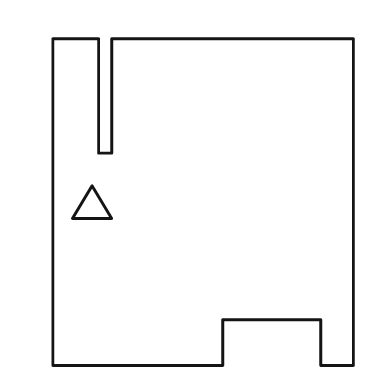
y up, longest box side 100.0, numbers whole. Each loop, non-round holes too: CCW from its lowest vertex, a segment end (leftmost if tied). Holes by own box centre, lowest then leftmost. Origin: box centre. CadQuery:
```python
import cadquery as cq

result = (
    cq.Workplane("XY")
    .moveTo(-46.0, -50.0)
    .lineTo(6.0, -50.0)
    .lineTo(6.0, -36.0)
    .lineTo(36.0, -36.0)
    .lineTo(36.0, -50.0)
    .lineTo(46.0, -50.0)
    .lineTo(46.0, 50.0)
    .lineTo(-28.0, 50.0)
    .lineTo(-28.0, 15.0)
    .lineTo(-32.0, 15.0)
    .lineTo(-32.0, 50.0)
    .lineTo(-46.0, 50.0)
    .close()
    .moveTo(-40.0, -5.0)
    .lineTo(-28.0, -5.0)
    .lineTo(-34.0, 5.0)
    .close()
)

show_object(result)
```